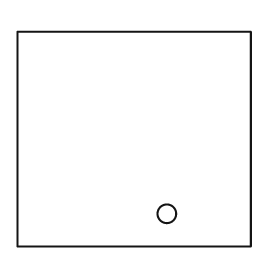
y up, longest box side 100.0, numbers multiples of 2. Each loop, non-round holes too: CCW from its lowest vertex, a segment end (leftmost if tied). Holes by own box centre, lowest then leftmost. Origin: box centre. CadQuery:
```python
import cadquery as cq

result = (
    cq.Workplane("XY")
    .moveTo(-50.0, -46.0)
    .lineTo(50.0, -46.0)
    .lineTo(50.0, 46.0)
    .lineTo(-50.0, 46.0)
    .close()
    .moveTo(14.0, -32.0)
    .circle(4.0)
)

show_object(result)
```